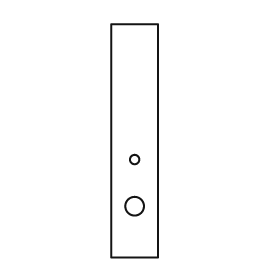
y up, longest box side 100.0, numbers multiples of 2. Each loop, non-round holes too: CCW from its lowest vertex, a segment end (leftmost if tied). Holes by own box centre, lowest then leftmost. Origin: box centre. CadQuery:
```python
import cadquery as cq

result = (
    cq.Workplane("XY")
    .moveTo(-10.0, -50.0)
    .lineTo(10.0, -50.0)
    .lineTo(10.0, 50.0)
    .lineTo(-10.0, 50.0)
    .close()
    .moveTo(0.0, -28.0)
    .circle(4.0)
    .moveTo(0.0, -8.0)
    .circle(2.0)
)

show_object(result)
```